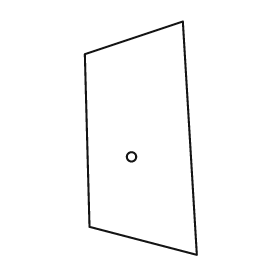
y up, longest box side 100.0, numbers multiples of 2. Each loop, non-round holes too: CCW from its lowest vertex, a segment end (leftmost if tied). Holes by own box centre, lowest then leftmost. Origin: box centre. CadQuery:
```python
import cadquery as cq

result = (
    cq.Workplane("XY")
    .moveTo(24.0, -50.0)
    .lineTo(18.0, 50.0)
    .lineTo(-24.0, 36.0)
    .lineTo(-22.0, -38.0)
    .close()
    .moveTo(-4.0, -8.0)
    .circle(2.0)
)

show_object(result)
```